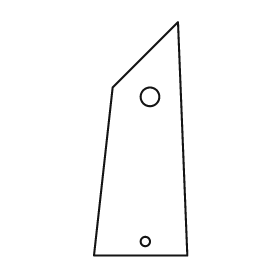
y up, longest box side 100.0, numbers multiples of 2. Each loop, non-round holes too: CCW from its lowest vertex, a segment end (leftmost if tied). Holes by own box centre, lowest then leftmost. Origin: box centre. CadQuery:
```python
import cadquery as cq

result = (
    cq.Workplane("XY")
    .moveTo(-20.0, -50.0)
    .lineTo(20.0, -50.0)
    .lineTo(16.0, 50.0)
    .lineTo(-12.0, 22.0)
    .close()
    .moveTo(2.0, -44.0)
    .circle(2.0)
    .moveTo(4.0, 18.0)
    .circle(4.0)
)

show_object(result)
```